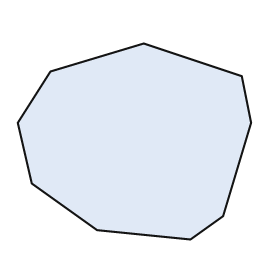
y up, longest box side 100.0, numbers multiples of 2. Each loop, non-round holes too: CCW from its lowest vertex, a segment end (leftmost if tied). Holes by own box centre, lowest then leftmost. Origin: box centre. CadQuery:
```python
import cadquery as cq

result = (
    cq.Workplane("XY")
    .moveTo(24.0, -42.0)
    .lineTo(38.0, -32.0)
    .lineTo(50.0, 8.0)
    .lineTo(46.0, 28.0)
    .lineTo(4.0, 42.0)
    .lineTo(-36.0, 30.0)
    .lineTo(-50.0, 8.0)
    .lineTo(-44.0, -18.0)
    .lineTo(-16.0, -38.0)
    .close()
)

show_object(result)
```